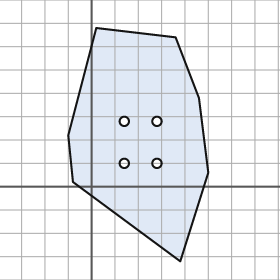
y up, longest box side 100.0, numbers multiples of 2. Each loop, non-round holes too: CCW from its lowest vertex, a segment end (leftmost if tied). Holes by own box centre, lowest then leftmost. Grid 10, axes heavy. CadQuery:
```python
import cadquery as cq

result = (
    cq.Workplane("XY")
    .moveTo(38.0, -32.0)
    .lineTo(50.0, 6.0)
    .lineTo(46.0, 38.0)
    .lineTo(36.0, 64.0)
    .lineTo(2.0, 68.0)
    .lineTo(-10.0, 22.0)
    .lineTo(-8.0, 2.0)
    .close()
    .moveTo(14.0, 10.0)
    .circle(2.0)
    .moveTo(28.0, 10.0)
    .circle(2.0)
    .moveTo(14.0, 28.0)
    .circle(2.0)
    .moveTo(28.0, 28.0)
    .circle(2.0)
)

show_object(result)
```